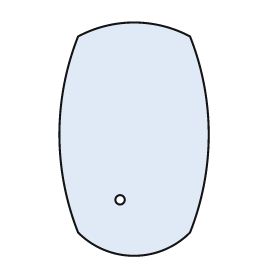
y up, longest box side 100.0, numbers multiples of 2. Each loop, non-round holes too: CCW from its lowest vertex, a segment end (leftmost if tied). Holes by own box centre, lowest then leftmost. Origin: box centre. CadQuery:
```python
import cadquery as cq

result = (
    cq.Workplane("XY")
    .moveTo(-24.0, -40.0)
    .threePointArc((0.0, -50.0), (24.0, -40.0))
    .threePointArc((32.0, 2.0), (24.0, 44.0))
    .threePointArc((0.0, 50.0), (-24.0, 44.0))
    .threePointArc((-32.0, 2.0), (-24.0, -40.0))
    .close()
    .moveTo(-6.0, -26.0)
    .circle(2.0)
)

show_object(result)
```